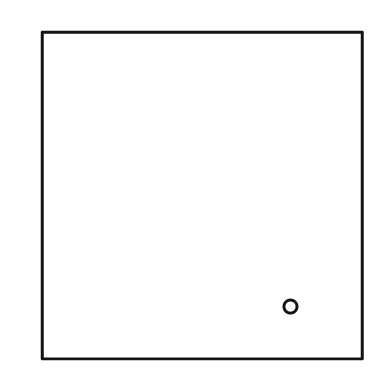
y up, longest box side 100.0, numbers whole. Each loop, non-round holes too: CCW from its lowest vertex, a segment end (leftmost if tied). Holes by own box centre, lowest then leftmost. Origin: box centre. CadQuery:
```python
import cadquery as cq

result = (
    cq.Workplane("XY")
    .moveTo(-49.0, -50.0)
    .lineTo(49.0, -50.0)
    .lineTo(49.0, 50.0)
    .lineTo(-49.0, 50.0)
    .close()
    .moveTo(27.0, -34.0)
    .circle(2.0)
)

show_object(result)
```